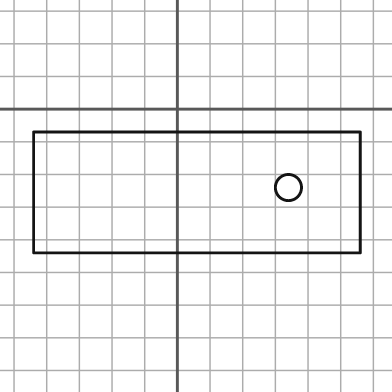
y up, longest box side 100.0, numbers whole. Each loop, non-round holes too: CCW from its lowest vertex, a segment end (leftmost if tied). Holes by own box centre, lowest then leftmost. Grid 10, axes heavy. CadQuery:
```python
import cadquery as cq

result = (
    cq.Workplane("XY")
    .moveTo(-44.0, -44.0)
    .lineTo(56.0, -44.0)
    .lineTo(56.0, -7.0)
    .lineTo(-44.0, -7.0)
    .close()
    .moveTo(34.0, -24.0)
    .circle(4.0)
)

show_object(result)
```